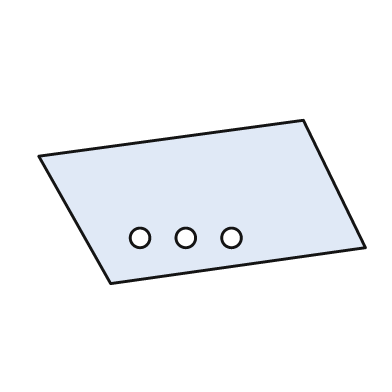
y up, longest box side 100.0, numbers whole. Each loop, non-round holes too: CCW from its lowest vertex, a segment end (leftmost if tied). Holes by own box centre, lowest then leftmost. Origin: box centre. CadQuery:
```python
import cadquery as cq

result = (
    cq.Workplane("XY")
    .moveTo(-28.0, -25.0)
    .lineTo(50.0, -14.0)
    .lineTo(31.0, 25.0)
    .lineTo(-50.0, 14.0)
    .close()
    .moveTo(-19.0, -11.0)
    .circle(3.0)
    .moveTo(-5.0, -11.0)
    .circle(3.0)
    .moveTo(9.0, -11.0)
    .circle(3.0)
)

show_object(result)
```